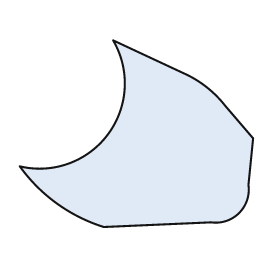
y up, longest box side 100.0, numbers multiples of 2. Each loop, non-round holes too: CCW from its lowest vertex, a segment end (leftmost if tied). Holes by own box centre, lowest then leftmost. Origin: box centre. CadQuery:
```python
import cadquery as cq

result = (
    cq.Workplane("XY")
    .moveTo(-14.0, -40.0)
    .lineTo(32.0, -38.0)
    .threePointArc((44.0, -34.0), (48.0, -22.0))
    .lineTo(50.0, -2.0)
    .lineTo(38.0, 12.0)
    .threePointArc((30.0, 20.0), (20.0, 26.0))
    .lineTo(-10.0, 40.0)
    .threePointArc((-12.0, 0.0), (-50.0, -14.0))
    .threePointArc((-34.0, -30.0), (-14.0, -40.0))
    .close()
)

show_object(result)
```